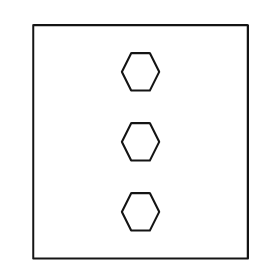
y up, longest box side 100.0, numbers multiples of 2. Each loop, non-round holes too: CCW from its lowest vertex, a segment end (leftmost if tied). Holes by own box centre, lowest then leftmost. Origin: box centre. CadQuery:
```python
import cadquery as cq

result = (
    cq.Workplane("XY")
    .moveTo(-46.0, -50.0)
    .lineTo(46.0, -50.0)
    .lineTo(46.0, 50.0)
    .lineTo(-46.0, 50.0)
    .close()
    .moveTo(-4.0, -38.0)
    .lineTo(4.0, -38.0)
    .lineTo(8.0, -30.0)
    .lineTo(4.0, -22.0)
    .lineTo(-4.0, -22.0)
    .lineTo(-8.0, -30.0)
    .close()
    .moveTo(-4.0, -8.0)
    .lineTo(4.0, -8.0)
    .lineTo(8.0, 0.0)
    .lineTo(4.0, 8.0)
    .lineTo(-4.0, 8.0)
    .lineTo(-8.0, 0.0)
    .close()
    .moveTo(-4.0, 22.0)
    .lineTo(4.0, 22.0)
    .lineTo(8.0, 30.0)
    .lineTo(4.0, 38.0)
    .lineTo(-4.0, 38.0)
    .lineTo(-8.0, 30.0)
    .close()
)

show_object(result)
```